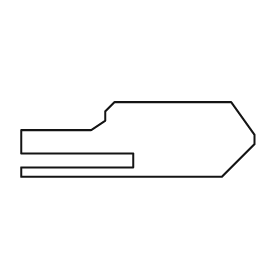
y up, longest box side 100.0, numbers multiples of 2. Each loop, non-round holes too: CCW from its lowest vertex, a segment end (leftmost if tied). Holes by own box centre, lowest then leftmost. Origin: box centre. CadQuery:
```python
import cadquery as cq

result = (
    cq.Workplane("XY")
    .moveTo(-50.0, -16.0)
    .lineTo(36.0, -16.0)
    .lineTo(50.0, -2.0)
    .lineTo(50.0, 2.0)
    .lineTo(40.0, 16.0)
    .lineTo(-10.0, 16.0)
    .lineTo(-14.0, 12.0)
    .lineTo(-14.0, 8.0)
    .lineTo(-20.0, 4.0)
    .lineTo(-50.0, 4.0)
    .lineTo(-50.0, -6.0)
    .lineTo(-2.0, -6.0)
    .lineTo(-2.0, -12.0)
    .lineTo(-50.0, -12.0)
    .close()
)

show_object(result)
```